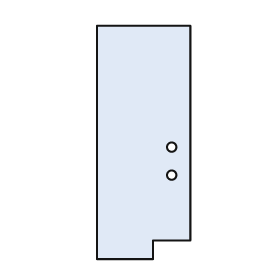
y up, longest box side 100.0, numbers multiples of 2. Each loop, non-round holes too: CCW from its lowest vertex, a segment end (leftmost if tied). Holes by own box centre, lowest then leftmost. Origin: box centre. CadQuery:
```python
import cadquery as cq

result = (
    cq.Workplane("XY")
    .moveTo(-20.0, -50.0)
    .lineTo(4.0, -50.0)
    .lineTo(4.0, -42.0)
    .lineTo(20.0, -42.0)
    .lineTo(20.0, 50.0)
    .lineTo(-20.0, 50.0)
    .close()
    .moveTo(12.0, -14.0)
    .circle(2.0)
    .moveTo(12.0, -2.0)
    .circle(2.0)
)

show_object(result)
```